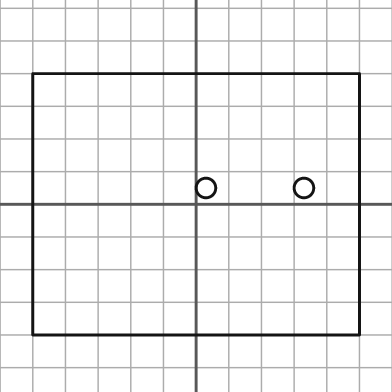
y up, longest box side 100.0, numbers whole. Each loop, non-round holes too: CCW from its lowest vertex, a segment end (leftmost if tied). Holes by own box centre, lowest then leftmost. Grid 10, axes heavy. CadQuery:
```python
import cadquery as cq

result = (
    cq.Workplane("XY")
    .moveTo(-50.0, -40.0)
    .lineTo(50.0, -40.0)
    .lineTo(50.0, 40.0)
    .lineTo(-50.0, 40.0)
    .close()
    .moveTo(3.0, 5.0)
    .circle(3.0)
    .moveTo(33.0, 5.0)
    .circle(3.0)
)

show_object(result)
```